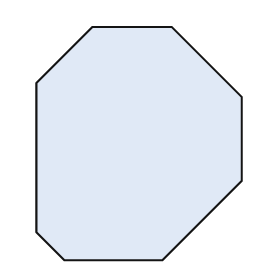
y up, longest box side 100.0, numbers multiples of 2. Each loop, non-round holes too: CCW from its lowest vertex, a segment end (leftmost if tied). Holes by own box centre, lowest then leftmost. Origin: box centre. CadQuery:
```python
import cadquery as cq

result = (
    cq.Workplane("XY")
    .moveTo(-32.0, -50.0)
    .lineTo(10.0, -50.0)
    .lineTo(44.0, -16.0)
    .lineTo(44.0, 20.0)
    .lineTo(14.0, 50.0)
    .lineTo(-20.0, 50.0)
    .lineTo(-44.0, 26.0)
    .lineTo(-44.0, -38.0)
    .close()
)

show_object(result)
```